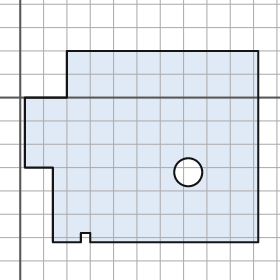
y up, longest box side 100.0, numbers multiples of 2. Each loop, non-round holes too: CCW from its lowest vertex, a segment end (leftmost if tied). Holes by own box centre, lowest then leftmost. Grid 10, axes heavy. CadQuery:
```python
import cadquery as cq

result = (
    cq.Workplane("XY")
    .moveTo(14.0, -62.0)
    .lineTo(26.0, -62.0)
    .lineTo(26.0, -58.0)
    .lineTo(30.0, -58.0)
    .lineTo(30.0, -62.0)
    .lineTo(102.0, -62.0)
    .lineTo(102.0, 20.0)
    .lineTo(20.0, 20.0)
    .lineTo(20.0, 0.0)
    .lineTo(2.0, 0.0)
    .lineTo(2.0, -30.0)
    .lineTo(14.0, -30.0)
    .close()
    .moveTo(72.0, -32.0)
    .circle(6.0)
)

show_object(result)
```